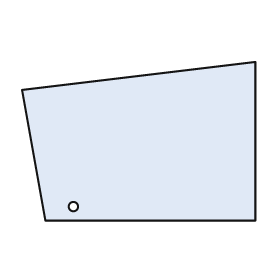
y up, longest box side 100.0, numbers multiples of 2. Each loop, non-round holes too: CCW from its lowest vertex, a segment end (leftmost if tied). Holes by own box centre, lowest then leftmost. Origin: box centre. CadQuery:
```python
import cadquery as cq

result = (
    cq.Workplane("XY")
    .moveTo(-40.0, -34.0)
    .lineTo(50.0, -34.0)
    .lineTo(50.0, 34.0)
    .lineTo(-50.0, 22.0)
    .close()
    .moveTo(-28.0, -28.0)
    .circle(2.0)
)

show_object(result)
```